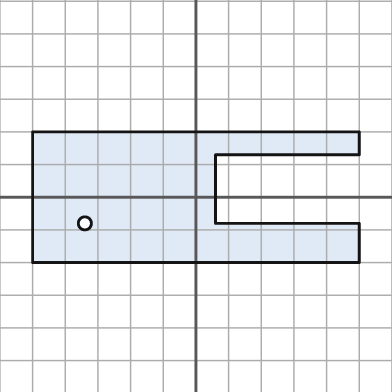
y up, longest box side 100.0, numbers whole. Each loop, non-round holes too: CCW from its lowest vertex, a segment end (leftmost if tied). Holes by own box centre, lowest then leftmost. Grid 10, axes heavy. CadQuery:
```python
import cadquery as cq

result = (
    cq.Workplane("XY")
    .moveTo(-50.0, -20.0)
    .lineTo(50.0, -20.0)
    .lineTo(50.0, -8.0)
    .lineTo(6.0, -8.0)
    .lineTo(6.0, 13.0)
    .lineTo(50.0, 13.0)
    .lineTo(50.0, 20.0)
    .lineTo(-50.0, 20.0)
    .close()
    .moveTo(-34.0, -8.0)
    .circle(2.0)
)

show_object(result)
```